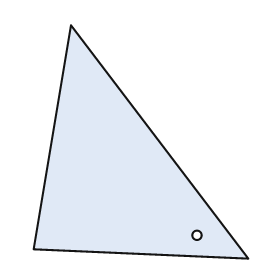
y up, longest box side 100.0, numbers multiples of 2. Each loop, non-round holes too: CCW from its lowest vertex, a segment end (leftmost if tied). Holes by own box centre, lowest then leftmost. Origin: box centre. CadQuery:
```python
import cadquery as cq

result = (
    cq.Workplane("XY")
    .moveTo(46.0, -50.0)
    .lineTo(-30.0, 50.0)
    .lineTo(-46.0, -46.0)
    .close()
    .moveTo(24.0, -40.0)
    .circle(2.0)
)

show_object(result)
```